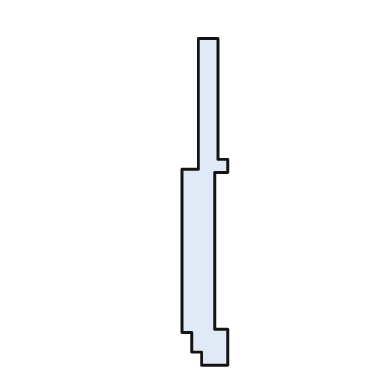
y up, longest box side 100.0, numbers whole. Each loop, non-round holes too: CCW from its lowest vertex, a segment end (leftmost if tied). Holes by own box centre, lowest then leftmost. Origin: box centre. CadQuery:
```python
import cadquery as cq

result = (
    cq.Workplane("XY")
    .moveTo(-1.0, -50.0)
    .lineTo(7.0, -50.0)
    .lineTo(7.0, -39.0)
    .lineTo(3.0, -39.0)
    .lineTo(3.0, 9.0)
    .lineTo(7.0, 9.0)
    .lineTo(7.0, 13.0)
    .lineTo(4.0, 13.0)
    .lineTo(4.0, 50.0)
    .lineTo(-2.0, 50.0)
    .lineTo(-2.0, 10.0)
    .lineTo(-7.0, 10.0)
    .lineTo(-7.0, -40.0)
    .lineTo(-4.0, -40.0)
    .lineTo(-4.0, -46.0)
    .lineTo(-1.0, -46.0)
    .close()
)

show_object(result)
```